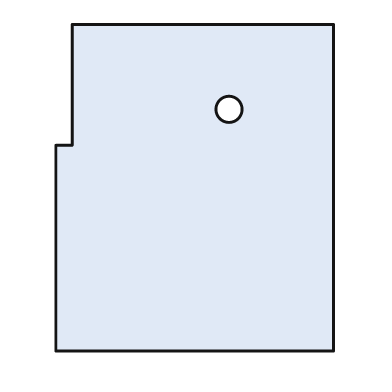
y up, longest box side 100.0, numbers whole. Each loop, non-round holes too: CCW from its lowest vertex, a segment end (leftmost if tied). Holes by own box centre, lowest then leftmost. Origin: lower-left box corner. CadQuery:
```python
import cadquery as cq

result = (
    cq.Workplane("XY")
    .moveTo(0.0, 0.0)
    .lineTo(85.0, 0.0)
    .lineTo(85.0, 100.0)
    .lineTo(5.0, 100.0)
    .lineTo(5.0, 63.0)
    .lineTo(0.0, 63.0)
    .close()
    .moveTo(53.0, 74.0)
    .circle(4.0)
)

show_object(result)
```